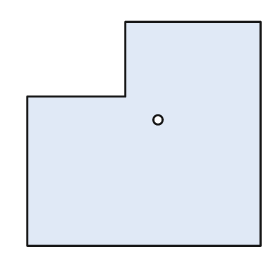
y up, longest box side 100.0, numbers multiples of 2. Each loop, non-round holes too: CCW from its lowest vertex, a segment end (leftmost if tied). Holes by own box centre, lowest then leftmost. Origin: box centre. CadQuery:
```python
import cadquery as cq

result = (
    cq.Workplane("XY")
    .moveTo(-50.0, -48.0)
    .lineTo(50.0, -48.0)
    .lineTo(50.0, 48.0)
    .lineTo(-8.0, 48.0)
    .lineTo(-8.0, 16.0)
    .lineTo(-50.0, 16.0)
    .close()
    .moveTo(6.0, 6.0)
    .circle(2.0)
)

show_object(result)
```